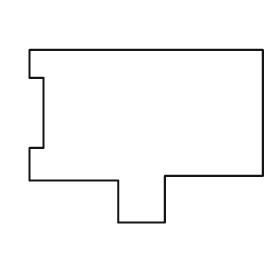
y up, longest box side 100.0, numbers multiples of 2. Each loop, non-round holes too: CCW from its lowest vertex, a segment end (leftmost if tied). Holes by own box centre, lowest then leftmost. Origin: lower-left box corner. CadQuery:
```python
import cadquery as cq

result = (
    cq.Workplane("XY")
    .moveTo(38.0, 0.0)
    .lineTo(58.0, 0.0)
    .lineTo(58.0, 20.0)
    .lineTo(100.0, 20.0)
    .lineTo(100.0, 74.0)
    .lineTo(0.0, 74.0)
    .lineTo(0.0, 62.0)
    .lineTo(6.0, 62.0)
    .lineTo(6.0, 32.0)
    .lineTo(0.0, 32.0)
    .lineTo(0.0, 18.0)
    .lineTo(38.0, 18.0)
    .close()
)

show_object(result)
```